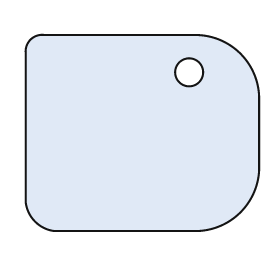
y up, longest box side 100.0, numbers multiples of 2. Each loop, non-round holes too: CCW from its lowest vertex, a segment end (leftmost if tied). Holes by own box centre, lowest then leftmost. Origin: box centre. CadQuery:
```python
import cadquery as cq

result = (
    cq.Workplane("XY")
    .moveTo(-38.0, -42.0)
    .lineTo(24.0, -42.0)
    .threePointArc((42.0, -34.0), (50.0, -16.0))
    .lineTo(50.0, 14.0)
    .threePointArc((42.0, 34.0), (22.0, 42.0))
    .lineTo(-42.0, 42.0)
    .threePointArc((-48.0, 40.0), (-50.0, 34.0))
    .lineTo(-50.0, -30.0)
    .threePointArc((-46.0, -38.0), (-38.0, -42.0))
    .close()
    .moveTo(20.0, 26.0)
    .circle(6.0)
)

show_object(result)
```